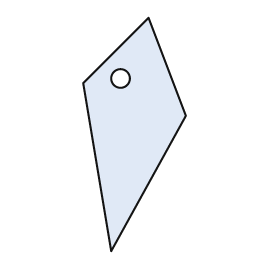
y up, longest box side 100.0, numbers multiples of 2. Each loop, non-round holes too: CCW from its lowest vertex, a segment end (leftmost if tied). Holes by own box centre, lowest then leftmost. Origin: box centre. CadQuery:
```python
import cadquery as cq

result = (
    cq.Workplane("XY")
    .moveTo(-10.0, -50.0)
    .lineTo(22.0, 8.0)
    .lineTo(6.0, 50.0)
    .lineTo(-22.0, 22.0)
    .close()
    .moveTo(-6.0, 24.0)
    .circle(4.0)
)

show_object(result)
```